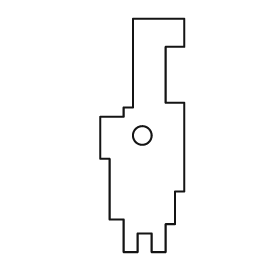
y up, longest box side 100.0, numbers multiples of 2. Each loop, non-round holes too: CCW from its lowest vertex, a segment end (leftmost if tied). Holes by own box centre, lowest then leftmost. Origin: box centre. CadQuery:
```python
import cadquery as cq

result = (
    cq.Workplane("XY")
    .moveTo(-8.0, -50.0)
    .lineTo(-2.0, -50.0)
    .lineTo(-2.0, -42.0)
    .lineTo(4.0, -42.0)
    .lineTo(4.0, -50.0)
    .lineTo(10.0, -50.0)
    .lineTo(10.0, -38.0)
    .lineTo(14.0, -38.0)
    .lineTo(14.0, -24.0)
    .lineTo(18.0, -24.0)
    .lineTo(18.0, 14.0)
    .lineTo(10.0, 14.0)
    .lineTo(10.0, 38.0)
    .lineTo(18.0, 38.0)
    .lineTo(18.0, 50.0)
    .lineTo(-4.0, 50.0)
    .lineTo(-4.0, 12.0)
    .lineTo(-8.0, 12.0)
    .lineTo(-8.0, 8.0)
    .lineTo(-18.0, 8.0)
    .lineTo(-18.0, -10.0)
    .lineTo(-14.0, -10.0)
    .lineTo(-14.0, -36.0)
    .lineTo(-8.0, -36.0)
    .close()
    .moveTo(0.0, 0.0)
    .circle(4.0)
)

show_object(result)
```